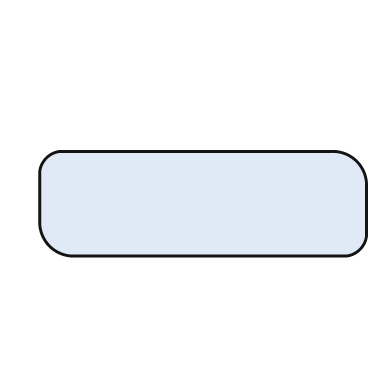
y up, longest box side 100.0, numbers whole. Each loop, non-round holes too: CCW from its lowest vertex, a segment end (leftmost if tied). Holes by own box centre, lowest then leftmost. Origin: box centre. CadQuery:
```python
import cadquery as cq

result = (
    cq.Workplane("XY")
    .moveTo(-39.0, -16.0)
    .lineTo(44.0, -16.0)
    .threePointArc((48.0, -14.0), (50.0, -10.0))
    .lineTo(50.0, 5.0)
    .threePointArc((47.0, 13.0), (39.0, 16.0))
    .lineTo(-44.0, 16.0)
    .threePointArc((-48.0, 14.0), (-50.0, 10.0))
    .lineTo(-50.0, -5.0)
    .threePointArc((-47.0, -13.0), (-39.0, -16.0))
    .close()
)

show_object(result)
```